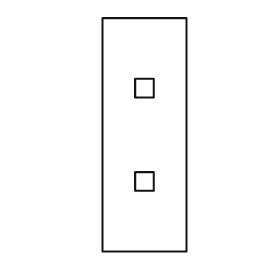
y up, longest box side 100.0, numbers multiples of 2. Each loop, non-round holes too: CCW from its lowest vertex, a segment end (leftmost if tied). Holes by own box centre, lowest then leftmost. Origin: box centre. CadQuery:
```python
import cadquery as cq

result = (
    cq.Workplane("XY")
    .moveTo(-18.0, -50.0)
    .lineTo(18.0, -50.0)
    .lineTo(18.0, 50.0)
    .lineTo(-18.0, 50.0)
    .close()
    .moveTo(-4.0, -24.0)
    .lineTo(4.0, -24.0)
    .lineTo(4.0, -16.0)
    .lineTo(-4.0, -16.0)
    .close()
    .moveTo(-4.0, 16.0)
    .lineTo(4.0, 16.0)
    .lineTo(4.0, 24.0)
    .lineTo(-4.0, 24.0)
    .close()
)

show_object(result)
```